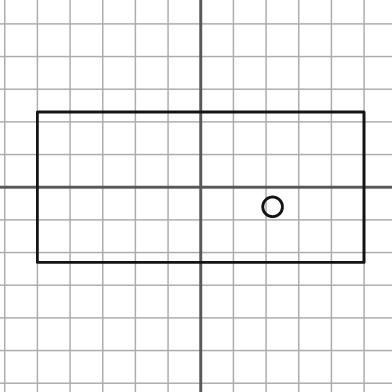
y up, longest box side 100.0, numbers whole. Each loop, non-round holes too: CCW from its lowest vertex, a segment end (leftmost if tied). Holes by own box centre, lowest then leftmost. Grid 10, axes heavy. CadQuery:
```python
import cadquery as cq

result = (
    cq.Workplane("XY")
    .moveTo(-50.0, -23.0)
    .lineTo(50.0, -23.0)
    .lineTo(50.0, 23.0)
    .lineTo(-50.0, 23.0)
    .close()
    .moveTo(22.0, -6.0)
    .circle(3.0)
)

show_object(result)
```